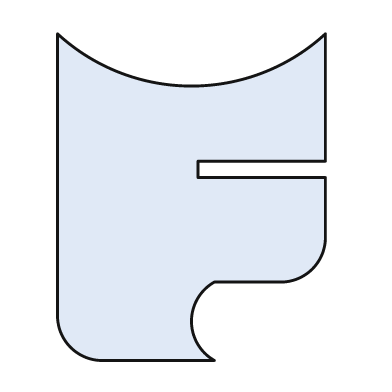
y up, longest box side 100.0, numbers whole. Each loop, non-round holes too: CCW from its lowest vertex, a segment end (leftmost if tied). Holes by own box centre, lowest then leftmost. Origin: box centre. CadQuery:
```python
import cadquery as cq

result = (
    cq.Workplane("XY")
    .moveTo(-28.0, -50.0)
    .lineTo(7.0, -50.0)
    .threePointArc((0.0, -38.0), (7.0, -26.0))
    .lineTo(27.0, -26.0)
    .threePointArc((37.0, -22.0), (41.0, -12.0))
    .lineTo(41.0, 6.0)
    .lineTo(2.0, 6.0)
    .lineTo(2.0, 11.0)
    .lineTo(41.0, 11.0)
    .lineTo(41.0, 50.0)
    .threePointArc((0.0, 34.0), (-41.0, 50.0))
    .lineTo(-41.0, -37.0)
    .threePointArc((-37.0, -46.0), (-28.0, -50.0))
    .close()
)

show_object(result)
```